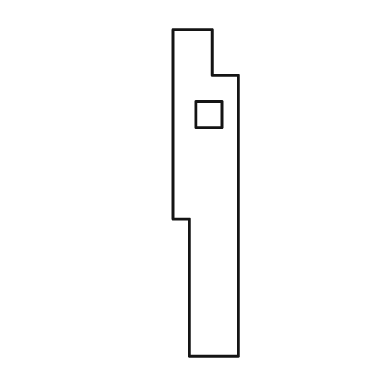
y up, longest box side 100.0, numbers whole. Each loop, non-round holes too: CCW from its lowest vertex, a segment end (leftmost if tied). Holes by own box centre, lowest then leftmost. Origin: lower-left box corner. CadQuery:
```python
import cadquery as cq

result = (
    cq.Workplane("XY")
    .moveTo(5.0, 0.0)
    .lineTo(20.0, 0.0)
    .lineTo(20.0, 86.0)
    .lineTo(12.0, 86.0)
    .lineTo(12.0, 100.0)
    .lineTo(0.0, 100.0)
    .lineTo(0.0, 42.0)
    .lineTo(5.0, 42.0)
    .close()
    .moveTo(7.0, 70.0)
    .lineTo(15.0, 70.0)
    .lineTo(15.0, 78.0)
    .lineTo(7.0, 78.0)
    .close()
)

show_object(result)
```